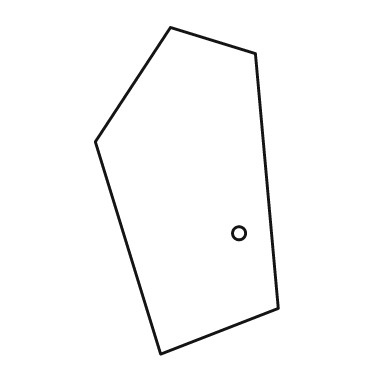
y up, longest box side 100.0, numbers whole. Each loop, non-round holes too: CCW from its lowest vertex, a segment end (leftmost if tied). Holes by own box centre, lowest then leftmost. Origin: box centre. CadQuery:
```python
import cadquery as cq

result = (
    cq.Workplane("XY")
    .moveTo(-8.0, -50.0)
    .lineTo(28.0, -36.0)
    .lineTo(21.0, 42.0)
    .lineTo(-5.0, 50.0)
    .lineTo(-28.0, 15.0)
    .close()
    .moveTo(16.0, -13.0)
    .circle(2.0)
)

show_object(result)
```